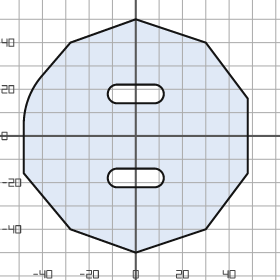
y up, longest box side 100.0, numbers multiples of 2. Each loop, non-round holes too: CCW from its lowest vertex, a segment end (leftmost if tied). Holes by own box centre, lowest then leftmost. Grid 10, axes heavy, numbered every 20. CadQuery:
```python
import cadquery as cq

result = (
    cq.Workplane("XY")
    .moveTo(0.0, -50.0)
    .lineTo(30.0, -40.0)
    .lineTo(48.0, -16.0)
    .lineTo(48.0, 16.0)
    .lineTo(30.0, 40.0)
    .lineTo(0.0, 50.0)
    .lineTo(-28.0, 40.0)
    .lineTo(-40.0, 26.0)
    .threePointArc((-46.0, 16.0), (-48.0, 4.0))
    .lineTo(-48.0, -16.0)
    .lineTo(-28.0, -40.0)
    .close()
    .moveTo(-8.0, -22.0)
    .lineTo(8.0, -22.0)
    .threePointArc((12.0, -18.0), (8.0, -14.0))
    .lineTo(-8.0, -14.0)
    .threePointArc((-12.0, -18.0), (-8.0, -22.0))
    .close()
    .moveTo(-8.0, 14.0)
    .lineTo(8.0, 14.0)
    .threePointArc((12.0, 18.0), (8.0, 22.0))
    .lineTo(-8.0, 22.0)
    .threePointArc((-12.0, 18.0), (-8.0, 14.0))
    .close()
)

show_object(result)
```